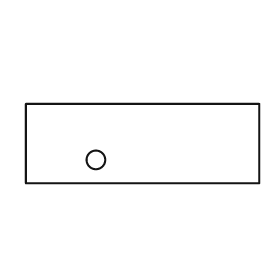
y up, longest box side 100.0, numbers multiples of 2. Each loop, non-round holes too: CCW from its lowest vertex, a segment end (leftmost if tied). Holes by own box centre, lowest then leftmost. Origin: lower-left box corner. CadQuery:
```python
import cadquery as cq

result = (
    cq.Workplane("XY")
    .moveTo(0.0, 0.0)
    .lineTo(100.0, 0.0)
    .lineTo(100.0, 34.0)
    .lineTo(0.0, 34.0)
    .close()
    .moveTo(30.0, 10.0)
    .circle(4.0)
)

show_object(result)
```